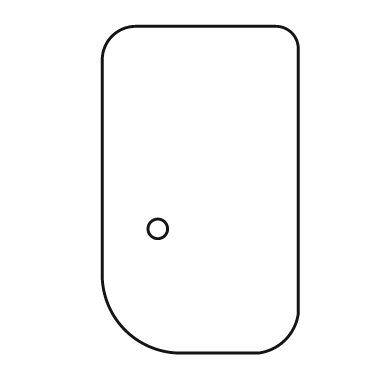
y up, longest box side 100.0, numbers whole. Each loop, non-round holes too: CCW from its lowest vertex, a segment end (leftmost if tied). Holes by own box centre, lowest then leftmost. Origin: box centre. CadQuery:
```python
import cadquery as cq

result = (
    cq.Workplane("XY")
    .moveTo(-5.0, -50.0)
    .lineTo(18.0, -50.0)
    .threePointArc((26.0, -46.0), (30.0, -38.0))
    .lineTo(30.0, 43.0)
    .threePointArc((28.0, 48.0), (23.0, 50.0))
    .lineTo(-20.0, 50.0)
    .threePointArc((-27.0, 47.0), (-30.0, 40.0))
    .lineTo(-30.0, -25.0)
    .threePointArc((-23.0, -43.0), (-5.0, -50.0))
    .close()
    .moveTo(-13.0, -12.0)
    .circle(3.0)
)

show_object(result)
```